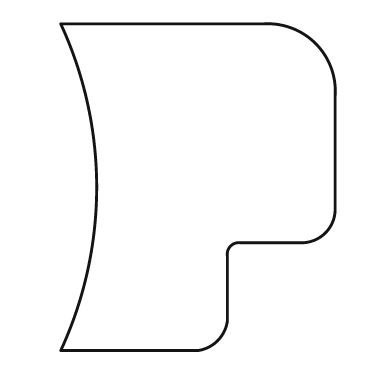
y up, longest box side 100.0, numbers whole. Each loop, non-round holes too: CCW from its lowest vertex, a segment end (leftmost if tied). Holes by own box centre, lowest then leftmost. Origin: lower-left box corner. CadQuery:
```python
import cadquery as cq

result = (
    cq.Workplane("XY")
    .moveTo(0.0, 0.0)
    .lineTo(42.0, 0.0)
    .threePointArc((48.0, 3.0), (51.0, 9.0))
    .lineTo(51.0, 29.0)
    .threePointArc((52.0, 32.0), (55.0, 33.0))
    .lineTo(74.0, 33.0)
    .threePointArc((81.0, 36.0), (84.0, 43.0))
    .lineTo(84.0, 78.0)
    .threePointArc((78.0, 94.0), (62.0, 100.0))
    .lineTo(0.0, 100.0)
    .threePointArc((11.0, 50.0), (0.0, 0.0))
    .close()
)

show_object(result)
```